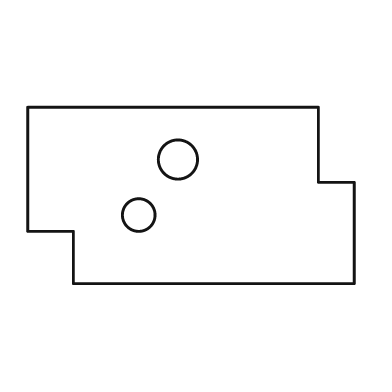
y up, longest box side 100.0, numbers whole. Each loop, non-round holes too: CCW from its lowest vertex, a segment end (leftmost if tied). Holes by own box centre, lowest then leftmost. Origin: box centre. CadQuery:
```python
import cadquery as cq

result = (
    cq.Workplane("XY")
    .moveTo(-36.0, -27.0)
    .lineTo(50.0, -27.0)
    .lineTo(50.0, 4.0)
    .lineTo(39.0, 4.0)
    .lineTo(39.0, 27.0)
    .lineTo(-50.0, 27.0)
    .lineTo(-50.0, -11.0)
    .lineTo(-36.0, -11.0)
    .close()
    .moveTo(-16.0, -6.0)
    .circle(5.0)
    .moveTo(-4.0, 11.0)
    .circle(6.0)
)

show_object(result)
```